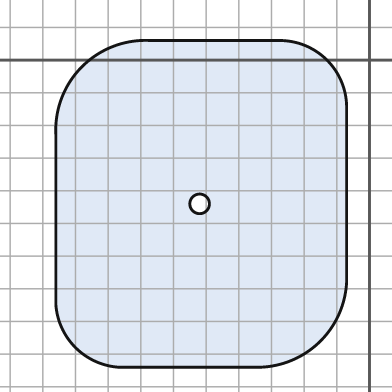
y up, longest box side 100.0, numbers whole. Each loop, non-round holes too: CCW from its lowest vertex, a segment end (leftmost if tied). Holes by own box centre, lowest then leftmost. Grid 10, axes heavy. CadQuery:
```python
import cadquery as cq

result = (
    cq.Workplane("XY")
    .moveTo(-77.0, -94.0)
    .lineTo(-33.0, -94.0)
    .threePointArc((-15.0, -86.0), (-7.0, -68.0))
    .lineTo(-7.0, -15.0)
    .threePointArc((-13.0, 0.0), (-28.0, 6.0))
    .lineTo(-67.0, 6.0)
    .threePointArc((-88.0, -2.0), (-96.0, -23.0))
    .lineTo(-96.0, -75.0)
    .threePointArc((-90.0, -88.0), (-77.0, -94.0))
    .close()
    .moveTo(-52.0, -44.0)
    .circle(3.0)
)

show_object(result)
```